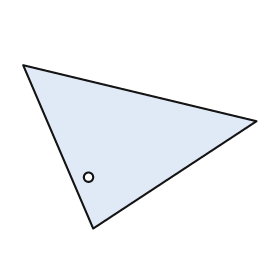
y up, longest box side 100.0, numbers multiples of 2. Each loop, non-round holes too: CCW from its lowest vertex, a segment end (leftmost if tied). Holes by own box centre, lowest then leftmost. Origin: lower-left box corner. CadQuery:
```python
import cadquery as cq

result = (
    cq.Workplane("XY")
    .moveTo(30.0, 0.0)
    .lineTo(100.0, 46.0)
    .lineTo(0.0, 70.0)
    .close()
    .moveTo(28.0, 22.0)
    .circle(2.0)
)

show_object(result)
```